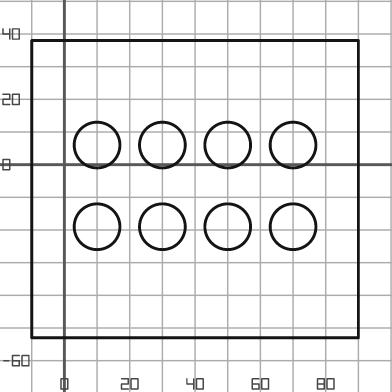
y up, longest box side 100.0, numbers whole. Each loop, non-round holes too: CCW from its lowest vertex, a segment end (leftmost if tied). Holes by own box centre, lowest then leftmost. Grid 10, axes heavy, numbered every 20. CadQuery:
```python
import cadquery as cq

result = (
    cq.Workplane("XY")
    .moveTo(-10.0, -53.0)
    .lineTo(90.0, -53.0)
    .lineTo(90.0, 38.0)
    .lineTo(-10.0, 38.0)
    .close()
    .moveTo(10.0, -19.0)
    .circle(7.0)
    .moveTo(30.0, -19.0)
    .circle(7.0)
    .moveTo(50.0, -19.0)
    .circle(7.0)
    .moveTo(70.0, -19.0)
    .circle(7.0)
    .moveTo(10.0, 6.0)
    .circle(7.0)
    .moveTo(30.0, 6.0)
    .circle(7.0)
    .moveTo(50.0, 6.0)
    .circle(7.0)
    .moveTo(70.0, 6.0)
    .circle(7.0)
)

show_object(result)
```